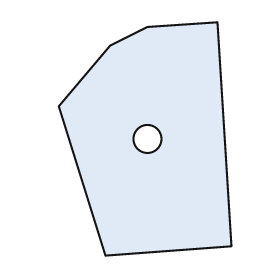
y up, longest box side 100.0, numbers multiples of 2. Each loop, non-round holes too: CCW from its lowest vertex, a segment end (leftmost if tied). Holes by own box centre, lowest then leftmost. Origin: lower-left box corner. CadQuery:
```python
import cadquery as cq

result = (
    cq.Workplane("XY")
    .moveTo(20.0, 0.0)
    .lineTo(74.0, 4.0)
    .lineTo(68.0, 100.0)
    .lineTo(38.0, 98.0)
    .lineTo(22.0, 90.0)
    .lineTo(0.0, 64.0)
    .close()
    .moveTo(38.0, 50.0)
    .circle(6.0)
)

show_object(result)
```